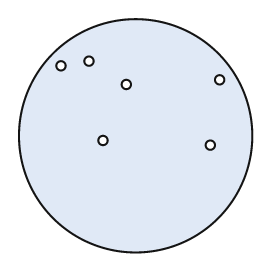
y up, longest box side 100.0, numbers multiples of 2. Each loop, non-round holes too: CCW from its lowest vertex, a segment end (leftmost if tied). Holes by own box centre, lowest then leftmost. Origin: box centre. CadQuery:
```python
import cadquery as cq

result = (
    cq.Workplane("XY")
    .moveTo(0.0, 0.0)
    .circle(50.0)
    .moveTo(32.0, -4.0)
    .circle(2.0)
    .moveTo(-14.0, -2.0)
    .circle(2.0)
    .moveTo(-4.0, 22.0)
    .circle(2.0)
    .moveTo(36.0, 24.0)
    .circle(2.0)
    .moveTo(-32.0, 30.0)
    .circle(2.0)
    .moveTo(-20.0, 32.0)
    .circle(2.0)
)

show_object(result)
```